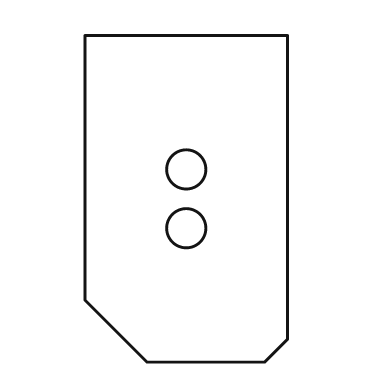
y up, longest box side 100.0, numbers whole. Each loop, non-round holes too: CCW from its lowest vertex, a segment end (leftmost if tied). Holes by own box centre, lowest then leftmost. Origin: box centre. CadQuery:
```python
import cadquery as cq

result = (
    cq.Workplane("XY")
    .moveTo(-12.0, -50.0)
    .lineTo(24.0, -50.0)
    .lineTo(31.0, -43.0)
    .lineTo(31.0, 50.0)
    .lineTo(-31.0, 50.0)
    .lineTo(-31.0, -31.0)
    .close()
    .moveTo(0.0, -9.0)
    .circle(6.0)
    .moveTo(0.0, 9.0)
    .circle(6.0)
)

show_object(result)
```